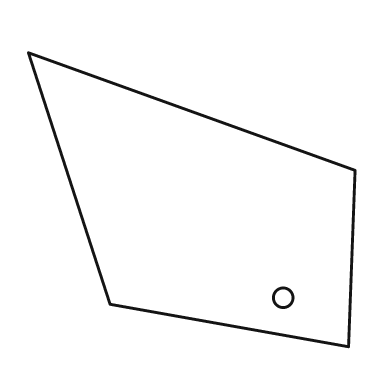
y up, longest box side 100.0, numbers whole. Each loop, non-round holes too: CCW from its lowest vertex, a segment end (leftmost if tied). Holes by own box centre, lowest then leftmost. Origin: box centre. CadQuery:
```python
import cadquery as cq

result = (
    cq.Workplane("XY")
    .moveTo(48.0, -45.0)
    .lineTo(50.0, 9.0)
    .lineTo(-50.0, 45.0)
    .lineTo(-25.0, -32.0)
    .close()
    .moveTo(28.0, -30.0)
    .circle(3.0)
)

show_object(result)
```